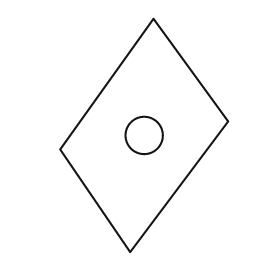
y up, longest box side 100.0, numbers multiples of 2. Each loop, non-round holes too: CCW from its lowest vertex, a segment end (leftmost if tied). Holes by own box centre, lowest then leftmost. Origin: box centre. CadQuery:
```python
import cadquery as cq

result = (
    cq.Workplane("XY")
    .moveTo(-6.0, -50.0)
    .lineTo(36.0, 6.0)
    .lineTo(4.0, 50.0)
    .lineTo(-36.0, -6.0)
    .close()
    .moveTo(0.0, 0.0)
    .circle(8.0)
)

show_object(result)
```